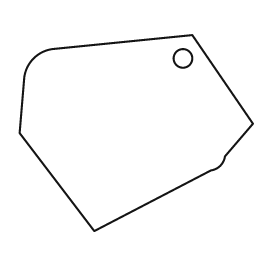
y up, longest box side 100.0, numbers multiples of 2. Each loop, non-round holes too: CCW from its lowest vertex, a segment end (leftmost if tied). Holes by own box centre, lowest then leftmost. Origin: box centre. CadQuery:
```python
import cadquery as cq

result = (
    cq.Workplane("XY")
    .moveTo(-18.0, -42.0)
    .lineTo(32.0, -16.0)
    .threePointArc((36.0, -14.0), (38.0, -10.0))
    .lineTo(50.0, 4.0)
    .lineTo(24.0, 42.0)
    .lineTo(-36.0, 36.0)
    .threePointArc((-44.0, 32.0), (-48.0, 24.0))
    .lineTo(-50.0, 0.0)
    .close()
    .moveTo(20.0, 32.0)
    .circle(4.0)
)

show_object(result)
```